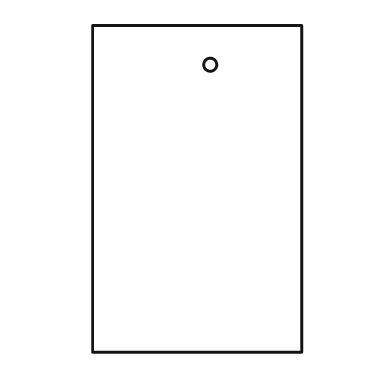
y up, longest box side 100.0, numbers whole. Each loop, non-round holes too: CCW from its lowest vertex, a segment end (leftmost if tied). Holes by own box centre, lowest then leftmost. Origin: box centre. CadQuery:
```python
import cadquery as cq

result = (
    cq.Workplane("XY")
    .moveTo(-32.0, -50.0)
    .lineTo(32.0, -50.0)
    .lineTo(32.0, 50.0)
    .lineTo(-32.0, 50.0)
    .close()
    .moveTo(4.0, 38.0)
    .circle(2.0)
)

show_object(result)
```